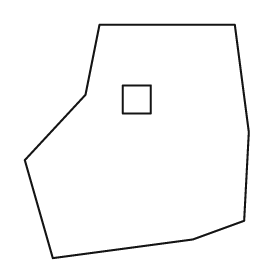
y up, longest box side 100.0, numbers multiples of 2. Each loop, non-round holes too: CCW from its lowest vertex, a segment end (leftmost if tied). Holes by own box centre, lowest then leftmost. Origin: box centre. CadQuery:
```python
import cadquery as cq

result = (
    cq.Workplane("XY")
    .moveTo(-36.0, -50.0)
    .lineTo(24.0, -42.0)
    .lineTo(46.0, -34.0)
    .lineTo(48.0, 4.0)
    .lineTo(42.0, 50.0)
    .lineTo(-16.0, 50.0)
    .lineTo(-22.0, 20.0)
    .lineTo(-48.0, -8.0)
    .close()
    .moveTo(-6.0, 12.0)
    .lineTo(6.0, 12.0)
    .lineTo(6.0, 24.0)
    .lineTo(-6.0, 24.0)
    .close()
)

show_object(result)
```